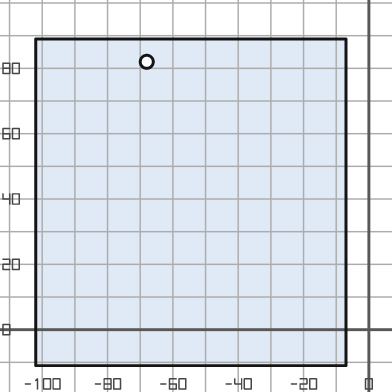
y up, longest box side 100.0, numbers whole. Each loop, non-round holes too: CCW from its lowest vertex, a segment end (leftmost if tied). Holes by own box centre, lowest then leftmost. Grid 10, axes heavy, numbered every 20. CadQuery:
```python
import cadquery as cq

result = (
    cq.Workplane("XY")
    .moveTo(-102.0, -11.0)
    .lineTo(-7.0, -11.0)
    .lineTo(-7.0, 89.0)
    .lineTo(-102.0, 89.0)
    .close()
    .moveTo(-68.0, 82.0)
    .circle(2.0)
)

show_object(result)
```